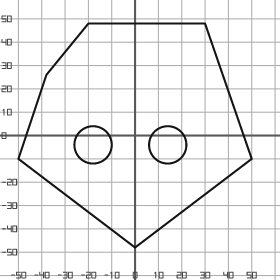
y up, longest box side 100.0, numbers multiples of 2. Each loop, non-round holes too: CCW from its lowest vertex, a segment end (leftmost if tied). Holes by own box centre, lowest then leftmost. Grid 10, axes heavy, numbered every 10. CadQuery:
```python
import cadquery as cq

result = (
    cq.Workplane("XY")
    .moveTo(0.0, -48.0)
    .lineTo(50.0, -10.0)
    .lineTo(30.0, 48.0)
    .lineTo(-20.0, 48.0)
    .lineTo(-38.0, 26.0)
    .lineTo(-50.0, -10.0)
    .close()
    .moveTo(-18.0, -4.0)
    .circle(8.0)
    .moveTo(14.0, -4.0)
    .circle(8.0)
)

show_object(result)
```